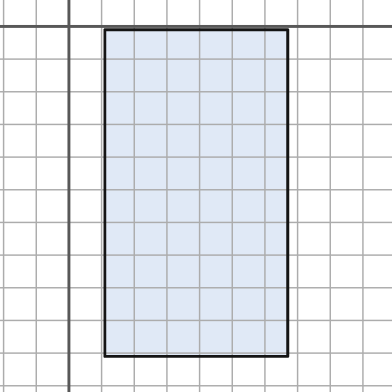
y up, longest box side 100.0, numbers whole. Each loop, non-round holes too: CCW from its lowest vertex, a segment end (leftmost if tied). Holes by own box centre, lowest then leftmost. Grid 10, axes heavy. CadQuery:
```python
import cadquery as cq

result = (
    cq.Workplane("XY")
    .moveTo(11.0, -101.0)
    .lineTo(67.0, -101.0)
    .lineTo(67.0, -1.0)
    .lineTo(11.0, -1.0)
    .close()
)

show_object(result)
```